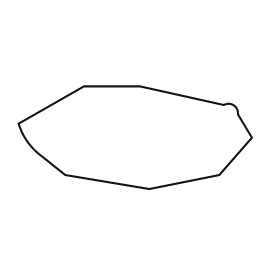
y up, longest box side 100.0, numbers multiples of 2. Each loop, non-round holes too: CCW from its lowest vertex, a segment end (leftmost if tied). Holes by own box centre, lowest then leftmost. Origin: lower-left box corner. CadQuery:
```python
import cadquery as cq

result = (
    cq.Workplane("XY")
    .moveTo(56.0, 0.0)
    .lineTo(86.0, 6.0)
    .lineTo(100.0, 22.0)
    .lineTo(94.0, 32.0)
    .threePointArc((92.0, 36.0), (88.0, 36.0))
    .lineTo(52.0, 44.0)
    .lineTo(28.0, 44.0)
    .lineTo(0.0, 28.0)
    .threePointArc((4.0, 20.0), (10.0, 14.0))
    .lineTo(20.0, 6.0)
    .close()
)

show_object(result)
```